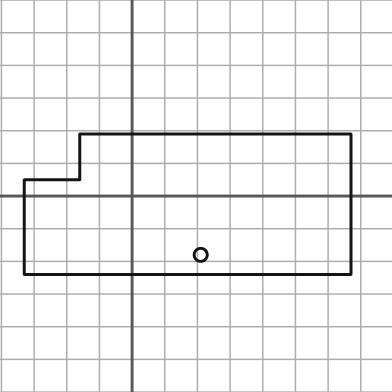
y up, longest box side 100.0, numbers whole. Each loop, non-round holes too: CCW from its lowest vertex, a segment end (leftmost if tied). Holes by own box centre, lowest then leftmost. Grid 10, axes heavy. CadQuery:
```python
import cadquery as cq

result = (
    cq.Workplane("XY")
    .moveTo(-33.0, -24.0)
    .lineTo(67.0, -24.0)
    .lineTo(67.0, 19.0)
    .lineTo(-16.0, 19.0)
    .lineTo(-16.0, 5.0)
    .lineTo(-33.0, 5.0)
    .close()
    .moveTo(21.0, -18.0)
    .circle(2.0)
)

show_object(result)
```